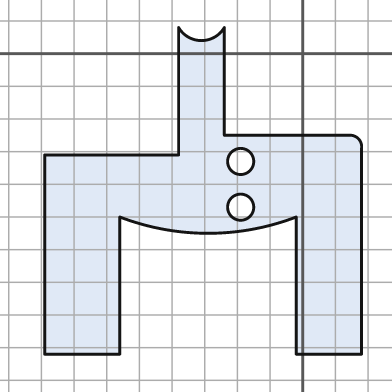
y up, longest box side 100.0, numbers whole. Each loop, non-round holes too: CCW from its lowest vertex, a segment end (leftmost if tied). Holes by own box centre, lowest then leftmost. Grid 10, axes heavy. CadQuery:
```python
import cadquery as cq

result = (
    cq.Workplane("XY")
    .moveTo(-79.0, -92.0)
    .lineTo(-56.0, -92.0)
    .lineTo(-56.0, -50.0)
    .threePointArc((-29.0, -55.0), (-2.0, -50.0))
    .lineTo(-2.0, -92.0)
    .lineTo(18.0, -92.0)
    .lineTo(18.0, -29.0)
    .threePointArc((17.0, -26.0), (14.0, -25.0))
    .lineTo(-24.0, -25.0)
    .lineTo(-24.0, 8.0)
    .threePointArc((-31.0, 4.0), (-38.0, 8.0))
    .lineTo(-38.0, -31.0)
    .lineTo(-79.0, -31.0)
    .close()
    .moveTo(-19.0, -47.0)
    .circle(4.0)
    .moveTo(-19.0, -33.0)
    .circle(4.0)
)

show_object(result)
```